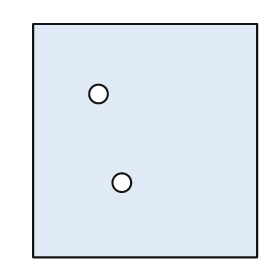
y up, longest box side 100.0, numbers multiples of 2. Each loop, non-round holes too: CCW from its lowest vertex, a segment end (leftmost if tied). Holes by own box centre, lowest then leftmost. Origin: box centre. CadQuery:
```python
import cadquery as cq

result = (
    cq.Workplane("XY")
    .moveTo(-48.0, -50.0)
    .lineTo(48.0, -50.0)
    .lineTo(48.0, 50.0)
    .lineTo(-48.0, 50.0)
    .close()
    .moveTo(-10.0, -18.0)
    .circle(4.0)
    .moveTo(-20.0, 20.0)
    .circle(4.0)
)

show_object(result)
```